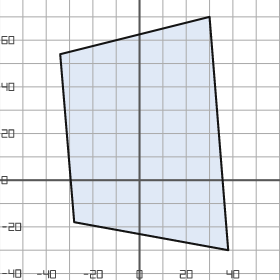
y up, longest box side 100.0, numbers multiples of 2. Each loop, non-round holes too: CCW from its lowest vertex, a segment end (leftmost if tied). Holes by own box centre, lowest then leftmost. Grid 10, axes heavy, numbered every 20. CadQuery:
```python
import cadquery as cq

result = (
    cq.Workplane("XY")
    .moveTo(38.0, -30.0)
    .lineTo(30.0, 70.0)
    .lineTo(-34.0, 54.0)
    .lineTo(-28.0, -18.0)
    .close()
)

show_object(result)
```